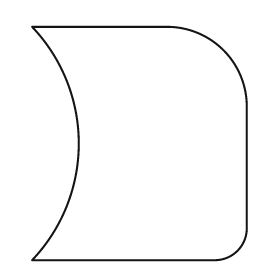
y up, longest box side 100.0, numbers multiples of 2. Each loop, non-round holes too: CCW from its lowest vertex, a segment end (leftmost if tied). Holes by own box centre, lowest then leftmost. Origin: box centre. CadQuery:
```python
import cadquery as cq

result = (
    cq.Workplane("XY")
    .moveTo(-46.0, -50.0)
    .lineTo(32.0, -50.0)
    .threePointArc((42.0, -46.0), (46.0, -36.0))
    .lineTo(46.0, 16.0)
    .threePointArc((36.0, 40.0), (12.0, 50.0))
    .lineTo(-46.0, 50.0)
    .threePointArc((-26.0, 0.0), (-46.0, -50.0))
    .close()
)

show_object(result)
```